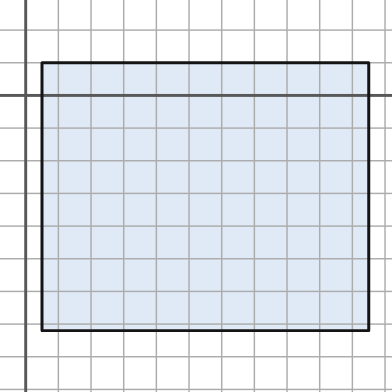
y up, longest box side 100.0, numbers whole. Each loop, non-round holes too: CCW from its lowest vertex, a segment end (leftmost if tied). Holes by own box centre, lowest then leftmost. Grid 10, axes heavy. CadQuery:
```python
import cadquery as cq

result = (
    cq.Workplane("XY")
    .moveTo(5.0, -72.0)
    .lineTo(105.0, -72.0)
    .lineTo(105.0, 10.0)
    .lineTo(5.0, 10.0)
    .close()
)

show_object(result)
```